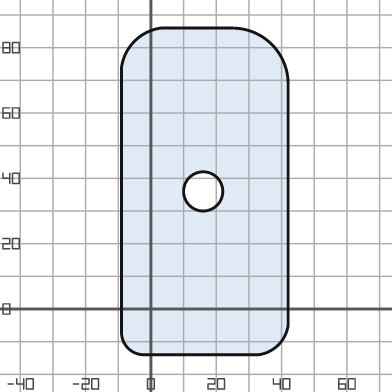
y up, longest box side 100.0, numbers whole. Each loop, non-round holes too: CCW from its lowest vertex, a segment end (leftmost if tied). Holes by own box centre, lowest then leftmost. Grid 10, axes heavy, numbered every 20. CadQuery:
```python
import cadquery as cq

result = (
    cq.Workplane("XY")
    .moveTo(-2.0, -14.0)
    .lineTo(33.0, -14.0)
    .threePointArc((39.0, -11.0), (42.0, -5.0))
    .lineTo(42.0, 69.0)
    .threePointArc((37.0, 81.0), (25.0, 86.0))
    .lineTo(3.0, 86.0)
    .threePointArc((-5.0, 82.0), (-9.0, 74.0))
    .lineTo(-9.0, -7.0)
    .threePointArc((-7.0, -12.0), (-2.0, -14.0))
    .close()
    .moveTo(16.0, 36.0)
    .circle(6.0)
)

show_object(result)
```